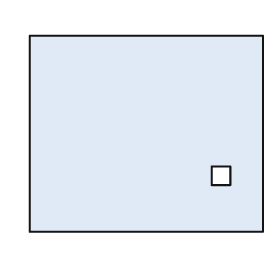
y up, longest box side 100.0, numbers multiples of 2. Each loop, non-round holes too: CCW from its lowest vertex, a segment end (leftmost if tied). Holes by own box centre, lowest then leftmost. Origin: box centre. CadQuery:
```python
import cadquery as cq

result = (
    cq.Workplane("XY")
    .moveTo(-50.0, -42.0)
    .lineTo(50.0, -42.0)
    .lineTo(50.0, 42.0)
    .lineTo(-50.0, 42.0)
    .close()
    .moveTo(28.0, -22.0)
    .lineTo(36.0, -22.0)
    .lineTo(36.0, -14.0)
    .lineTo(28.0, -14.0)
    .close()
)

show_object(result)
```